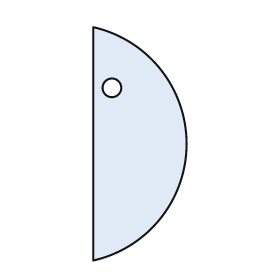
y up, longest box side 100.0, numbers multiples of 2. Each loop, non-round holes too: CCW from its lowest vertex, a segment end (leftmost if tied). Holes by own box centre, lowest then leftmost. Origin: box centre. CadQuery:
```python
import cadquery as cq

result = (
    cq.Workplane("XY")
    .moveTo(-20.0, -50.0)
    .threePointArc((20.0, 0.0), (-20.0, 50.0))
    .close()
    .moveTo(-12.0, 24.0)
    .circle(4.0)
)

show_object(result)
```